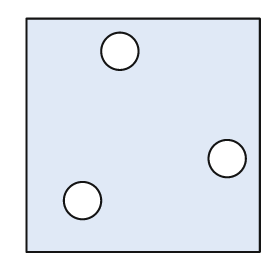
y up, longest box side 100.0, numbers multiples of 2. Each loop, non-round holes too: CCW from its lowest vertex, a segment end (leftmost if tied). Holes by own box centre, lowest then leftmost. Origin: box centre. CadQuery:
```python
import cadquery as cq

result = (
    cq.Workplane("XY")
    .moveTo(-50.0, -50.0)
    .lineTo(50.0, -50.0)
    .lineTo(50.0, 50.0)
    .lineTo(-50.0, 50.0)
    .close()
    .moveTo(-26.0, -28.0)
    .circle(8.0)
    .moveTo(36.0, -10.0)
    .circle(8.0)
    .moveTo(-10.0, 36.0)
    .circle(8.0)
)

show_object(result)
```